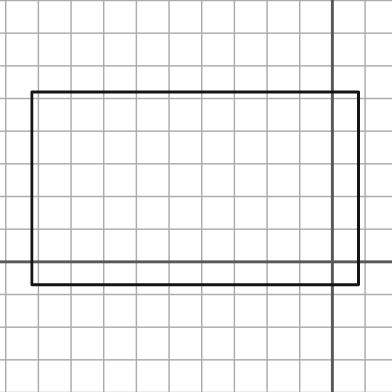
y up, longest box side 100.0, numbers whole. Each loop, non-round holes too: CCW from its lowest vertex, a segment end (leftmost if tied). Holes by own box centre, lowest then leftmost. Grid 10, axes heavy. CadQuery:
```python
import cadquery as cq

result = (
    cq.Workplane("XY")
    .moveTo(-92.0, -7.0)
    .lineTo(8.0, -7.0)
    .lineTo(8.0, 52.0)
    .lineTo(-92.0, 52.0)
    .close()
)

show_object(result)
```